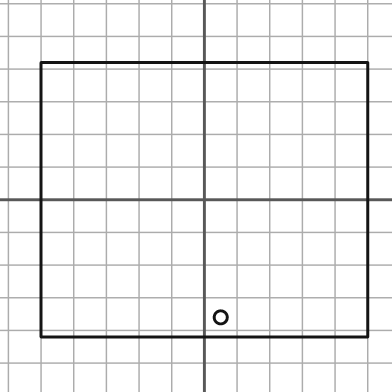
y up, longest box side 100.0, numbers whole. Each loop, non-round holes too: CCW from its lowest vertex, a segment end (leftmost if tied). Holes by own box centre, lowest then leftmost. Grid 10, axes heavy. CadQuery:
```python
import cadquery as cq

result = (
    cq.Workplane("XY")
    .moveTo(-50.0, -42.0)
    .lineTo(50.0, -42.0)
    .lineTo(50.0, 42.0)
    .lineTo(-50.0, 42.0)
    .close()
    .moveTo(5.0, -36.0)
    .circle(2.0)
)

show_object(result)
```